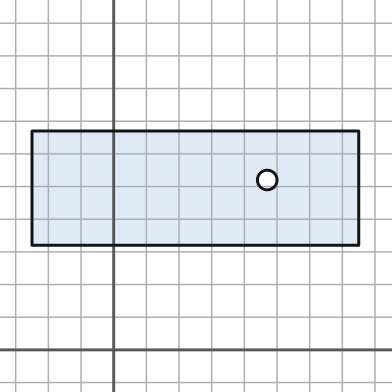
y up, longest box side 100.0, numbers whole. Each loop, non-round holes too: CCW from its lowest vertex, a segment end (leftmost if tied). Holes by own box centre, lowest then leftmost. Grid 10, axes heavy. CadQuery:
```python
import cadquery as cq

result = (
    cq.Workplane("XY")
    .moveTo(-25.0, 32.0)
    .lineTo(75.0, 32.0)
    .lineTo(75.0, 67.0)
    .lineTo(-25.0, 67.0)
    .close()
    .moveTo(47.0, 52.0)
    .circle(3.0)
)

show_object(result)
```